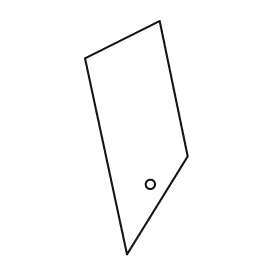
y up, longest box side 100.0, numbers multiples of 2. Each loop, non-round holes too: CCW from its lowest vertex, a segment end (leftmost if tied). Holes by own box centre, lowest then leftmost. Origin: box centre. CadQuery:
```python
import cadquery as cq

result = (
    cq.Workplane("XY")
    .moveTo(-4.0, -50.0)
    .lineTo(22.0, -8.0)
    .lineTo(10.0, 50.0)
    .lineTo(-22.0, 34.0)
    .close()
    .moveTo(6.0, -20.0)
    .circle(2.0)
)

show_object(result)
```